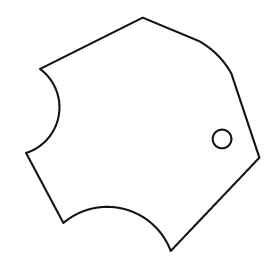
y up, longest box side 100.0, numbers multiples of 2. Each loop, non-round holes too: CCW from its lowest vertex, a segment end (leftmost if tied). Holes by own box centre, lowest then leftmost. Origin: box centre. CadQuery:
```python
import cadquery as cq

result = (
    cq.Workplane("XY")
    .moveTo(12.0, -50.0)
    .lineTo(50.0, -10.0)
    .lineTo(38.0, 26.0)
    .threePointArc((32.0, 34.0), (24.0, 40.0))
    .lineTo(0.0, 50.0)
    .lineTo(-44.0, 28.0)
    .threePointArc((-36.0, 8.0), (-50.0, -8.0))
    .lineTo(-34.0, -38.0)
    .threePointArc((-8.0, -32.0), (12.0, -50.0))
    .close()
    .moveTo(34.0, -2.0)
    .circle(4.0)
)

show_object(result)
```